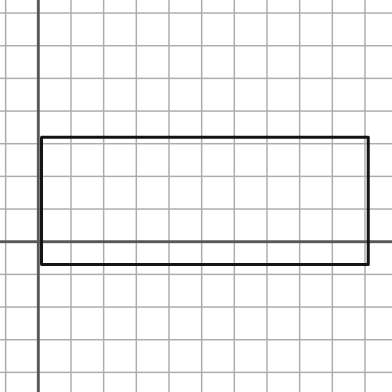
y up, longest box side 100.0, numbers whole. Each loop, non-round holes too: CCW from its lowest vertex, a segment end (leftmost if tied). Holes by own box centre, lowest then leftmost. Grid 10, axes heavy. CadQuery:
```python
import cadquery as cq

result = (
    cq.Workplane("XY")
    .moveTo(1.0, -7.0)
    .lineTo(101.0, -7.0)
    .lineTo(101.0, 32.0)
    .lineTo(1.0, 32.0)
    .close()
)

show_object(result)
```